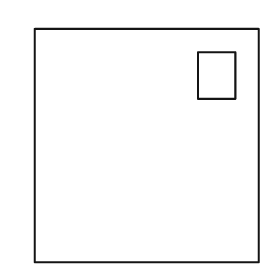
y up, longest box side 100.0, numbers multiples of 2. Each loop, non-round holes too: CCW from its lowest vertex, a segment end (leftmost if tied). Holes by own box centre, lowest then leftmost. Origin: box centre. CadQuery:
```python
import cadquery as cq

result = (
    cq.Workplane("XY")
    .moveTo(-48.0, -50.0)
    .lineTo(48.0, -50.0)
    .lineTo(48.0, 50.0)
    .lineTo(-48.0, 50.0)
    .close()
    .moveTo(22.0, 20.0)
    .lineTo(38.0, 20.0)
    .lineTo(38.0, 40.0)
    .lineTo(22.0, 40.0)
    .close()
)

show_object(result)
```